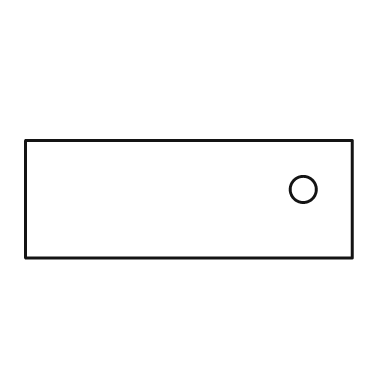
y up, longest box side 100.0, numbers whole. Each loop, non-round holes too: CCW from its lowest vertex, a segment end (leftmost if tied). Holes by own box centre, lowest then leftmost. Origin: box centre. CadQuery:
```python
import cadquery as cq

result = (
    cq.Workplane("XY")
    .moveTo(-50.0, -18.0)
    .lineTo(50.0, -18.0)
    .lineTo(50.0, 18.0)
    .lineTo(-50.0, 18.0)
    .close()
    .moveTo(35.0, 3.0)
    .circle(4.0)
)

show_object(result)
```